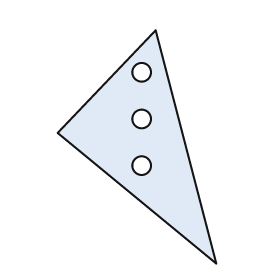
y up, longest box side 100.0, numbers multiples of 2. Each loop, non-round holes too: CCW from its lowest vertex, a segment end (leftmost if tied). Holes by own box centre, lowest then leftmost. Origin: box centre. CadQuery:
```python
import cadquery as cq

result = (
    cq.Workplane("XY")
    .moveTo(34.0, -50.0)
    .lineTo(8.0, 50.0)
    .lineTo(-34.0, 6.0)
    .close()
    .moveTo(2.0, -8.0)
    .circle(4.0)
    .moveTo(2.0, 12.0)
    .circle(4.0)
    .moveTo(2.0, 32.0)
    .circle(4.0)
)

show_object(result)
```